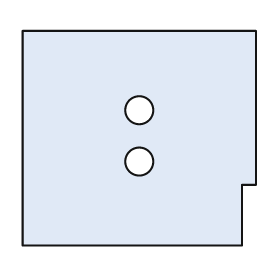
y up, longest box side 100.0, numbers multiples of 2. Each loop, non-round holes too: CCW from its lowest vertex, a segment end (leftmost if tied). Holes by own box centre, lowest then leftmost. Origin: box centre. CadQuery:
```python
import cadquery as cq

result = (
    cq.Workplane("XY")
    .moveTo(-50.0, -46.0)
    .lineTo(44.0, -46.0)
    .lineTo(44.0, -20.0)
    .lineTo(50.0, -20.0)
    .lineTo(50.0, 46.0)
    .lineTo(-50.0, 46.0)
    .close()
    .moveTo(0.0, -10.0)
    .circle(6.0)
    .moveTo(0.0, 12.0)
    .circle(6.0)
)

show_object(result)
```